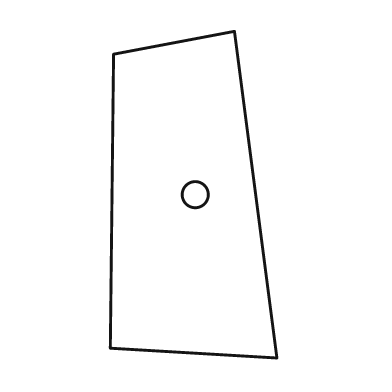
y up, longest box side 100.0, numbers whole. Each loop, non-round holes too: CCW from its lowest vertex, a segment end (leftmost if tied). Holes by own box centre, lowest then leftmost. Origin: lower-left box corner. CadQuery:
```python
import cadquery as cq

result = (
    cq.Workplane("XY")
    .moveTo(51.0, 0.0)
    .lineTo(38.0, 100.0)
    .lineTo(1.0, 93.0)
    .lineTo(0.0, 3.0)
    .close()
    .moveTo(26.0, 50.0)
    .circle(4.0)
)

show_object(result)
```